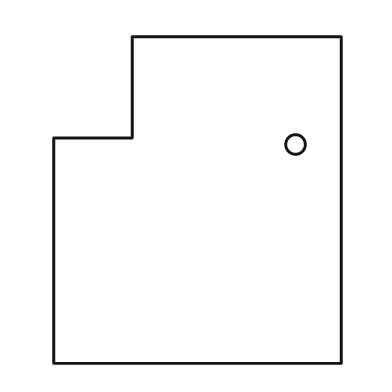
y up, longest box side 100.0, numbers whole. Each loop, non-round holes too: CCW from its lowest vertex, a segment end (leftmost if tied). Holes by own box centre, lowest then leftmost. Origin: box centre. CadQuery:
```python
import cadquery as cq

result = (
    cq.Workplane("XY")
    .moveTo(-44.0, -50.0)
    .lineTo(44.0, -50.0)
    .lineTo(44.0, 50.0)
    .lineTo(-20.0, 50.0)
    .lineTo(-20.0, 19.0)
    .lineTo(-44.0, 19.0)
    .close()
    .moveTo(30.0, 17.0)
    .circle(3.0)
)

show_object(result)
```